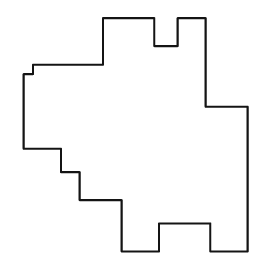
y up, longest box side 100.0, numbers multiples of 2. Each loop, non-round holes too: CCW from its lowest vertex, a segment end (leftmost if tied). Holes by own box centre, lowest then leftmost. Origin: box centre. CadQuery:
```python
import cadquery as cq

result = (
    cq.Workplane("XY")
    .moveTo(-6.0, -50.0)
    .lineTo(10.0, -50.0)
    .lineTo(10.0, -38.0)
    .lineTo(32.0, -38.0)
    .lineTo(32.0, -50.0)
    .lineTo(48.0, -50.0)
    .lineTo(48.0, 12.0)
    .lineTo(30.0, 12.0)
    .lineTo(30.0, 50.0)
    .lineTo(18.0, 50.0)
    .lineTo(18.0, 38.0)
    .lineTo(8.0, 38.0)
    .lineTo(8.0, 50.0)
    .lineTo(-14.0, 50.0)
    .lineTo(-14.0, 30.0)
    .lineTo(-44.0, 30.0)
    .lineTo(-44.0, 26.0)
    .lineTo(-48.0, 26.0)
    .lineTo(-48.0, -6.0)
    .lineTo(-32.0, -6.0)
    .lineTo(-32.0, -16.0)
    .lineTo(-24.0, -16.0)
    .lineTo(-24.0, -28.0)
    .lineTo(-6.0, -28.0)
    .close()
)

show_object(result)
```